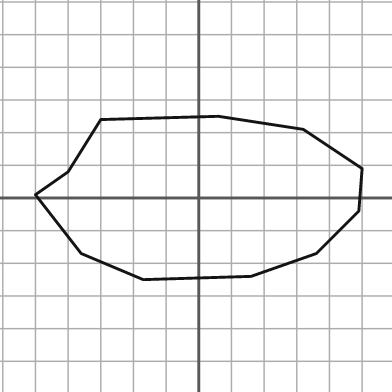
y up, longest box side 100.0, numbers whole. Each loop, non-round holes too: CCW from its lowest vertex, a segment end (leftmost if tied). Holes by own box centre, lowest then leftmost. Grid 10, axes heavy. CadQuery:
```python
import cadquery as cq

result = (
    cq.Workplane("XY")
    .moveTo(-17.0, -25.0)
    .lineTo(16.0, -24.0)
    .lineTo(36.0, -17.0)
    .lineTo(49.0, -4.0)
    .lineTo(50.0, 9.0)
    .lineTo(32.0, 21.0)
    .lineTo(6.0, 25.0)
    .lineTo(-30.0, 24.0)
    .lineTo(-40.0, 8.0)
    .lineTo(-50.0, 1.0)
    .lineTo(-36.0, -17.0)
    .close()
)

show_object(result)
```